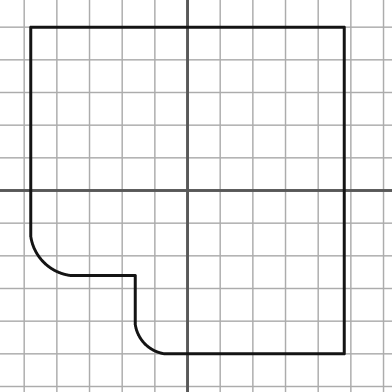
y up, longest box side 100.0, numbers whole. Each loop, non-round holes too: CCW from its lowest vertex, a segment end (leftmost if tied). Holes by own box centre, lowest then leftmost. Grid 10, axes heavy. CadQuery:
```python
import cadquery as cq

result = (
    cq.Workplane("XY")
    .moveTo(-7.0, -50.0)
    .lineTo(48.0, -50.0)
    .lineTo(48.0, 50.0)
    .lineTo(-48.0, 50.0)
    .lineTo(-48.0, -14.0)
    .threePointArc((-44.0, -22.0), (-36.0, -26.0))
    .lineTo(-16.0, -26.0)
    .lineTo(-16.0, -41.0)
    .threePointArc((-13.0, -47.0), (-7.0, -50.0))
    .close()
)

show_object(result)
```